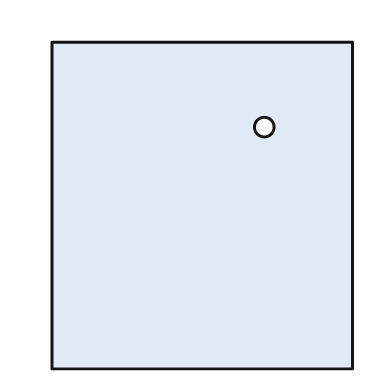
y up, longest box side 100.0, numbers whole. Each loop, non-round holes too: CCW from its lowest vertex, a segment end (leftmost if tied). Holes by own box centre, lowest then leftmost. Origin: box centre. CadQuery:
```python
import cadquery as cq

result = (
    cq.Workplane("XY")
    .moveTo(-46.0, -50.0)
    .lineTo(46.0, -50.0)
    .lineTo(46.0, 50.0)
    .lineTo(-46.0, 50.0)
    .close()
    .moveTo(19.0, 24.0)
    .circle(3.0)
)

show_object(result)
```